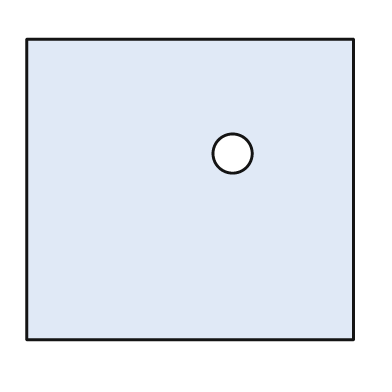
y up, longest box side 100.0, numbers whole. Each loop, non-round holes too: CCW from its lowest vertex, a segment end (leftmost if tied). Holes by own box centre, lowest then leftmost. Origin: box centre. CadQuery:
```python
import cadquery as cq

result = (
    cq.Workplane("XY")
    .moveTo(-50.0, -46.0)
    .lineTo(50.0, -46.0)
    .lineTo(50.0, 46.0)
    .lineTo(-50.0, 46.0)
    .close()
    .moveTo(13.0, 11.0)
    .circle(6.0)
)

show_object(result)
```